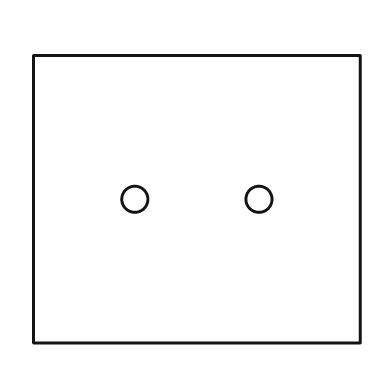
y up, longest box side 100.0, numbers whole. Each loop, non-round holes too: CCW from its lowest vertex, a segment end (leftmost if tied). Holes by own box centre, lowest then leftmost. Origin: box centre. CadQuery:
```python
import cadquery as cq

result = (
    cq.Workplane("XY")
    .moveTo(-50.0, -44.0)
    .lineTo(50.0, -44.0)
    .lineTo(50.0, 44.0)
    .lineTo(-50.0, 44.0)
    .close()
    .moveTo(-19.0, 0.0)
    .circle(4.0)
    .moveTo(19.0, 0.0)
    .circle(4.0)
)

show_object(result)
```